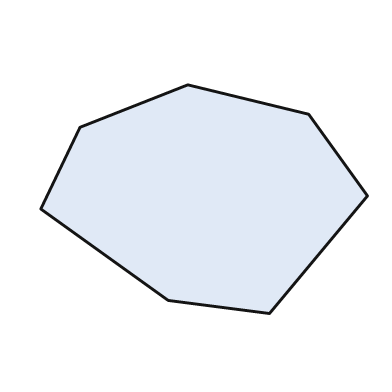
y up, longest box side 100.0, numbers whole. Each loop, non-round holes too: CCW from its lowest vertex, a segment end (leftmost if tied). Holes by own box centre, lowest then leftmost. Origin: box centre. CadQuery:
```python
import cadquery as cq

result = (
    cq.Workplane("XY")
    .moveTo(20.0, -35.0)
    .lineTo(50.0, 1.0)
    .lineTo(32.0, 26.0)
    .lineTo(-5.0, 35.0)
    .lineTo(-38.0, 22.0)
    .lineTo(-50.0, -3.0)
    .lineTo(-11.0, -31.0)
    .close()
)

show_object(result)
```